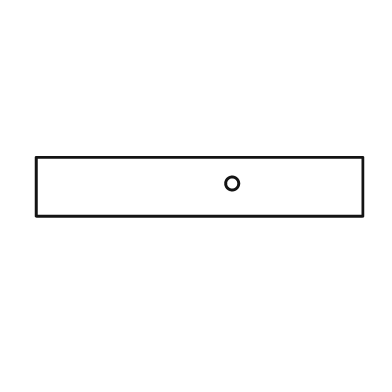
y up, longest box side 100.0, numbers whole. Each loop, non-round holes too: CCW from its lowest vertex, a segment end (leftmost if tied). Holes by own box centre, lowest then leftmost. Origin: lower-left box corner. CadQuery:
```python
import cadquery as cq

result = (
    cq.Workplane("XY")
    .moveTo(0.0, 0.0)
    .lineTo(100.0, 0.0)
    .lineTo(100.0, 18.0)
    .lineTo(0.0, 18.0)
    .close()
    .moveTo(60.0, 10.0)
    .circle(2.0)
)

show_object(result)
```